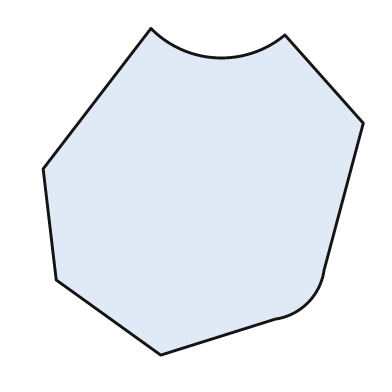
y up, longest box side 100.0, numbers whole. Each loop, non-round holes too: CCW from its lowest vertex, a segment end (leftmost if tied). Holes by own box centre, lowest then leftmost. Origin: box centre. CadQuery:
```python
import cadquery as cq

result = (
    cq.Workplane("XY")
    .moveTo(-13.0, -50.0)
    .lineTo(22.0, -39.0)
    .threePointArc((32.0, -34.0), (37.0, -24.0))
    .lineTo(49.0, 21.0)
    .lineTo(25.0, 48.0)
    .threePointArc((4.0, 41.0), (-16.0, 50.0))
    .lineTo(-49.0, 7.0)
    .lineTo(-45.0, -27.0)
    .close()
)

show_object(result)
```